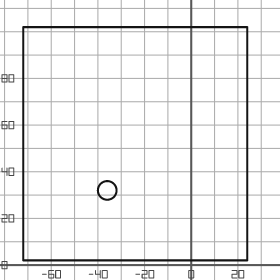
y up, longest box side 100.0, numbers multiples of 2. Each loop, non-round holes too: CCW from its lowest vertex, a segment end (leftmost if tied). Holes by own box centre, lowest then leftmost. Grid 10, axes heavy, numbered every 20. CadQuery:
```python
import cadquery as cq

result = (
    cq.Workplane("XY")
    .moveTo(-72.0, 2.0)
    .lineTo(24.0, 2.0)
    .lineTo(24.0, 102.0)
    .lineTo(-72.0, 102.0)
    .close()
    .moveTo(-36.0, 32.0)
    .circle(4.0)
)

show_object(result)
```